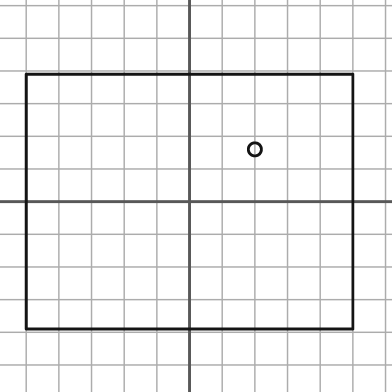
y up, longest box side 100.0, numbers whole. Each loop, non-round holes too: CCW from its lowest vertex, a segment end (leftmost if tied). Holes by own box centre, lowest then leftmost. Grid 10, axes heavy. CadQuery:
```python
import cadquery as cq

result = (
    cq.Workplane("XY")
    .moveTo(-50.0, -39.0)
    .lineTo(50.0, -39.0)
    .lineTo(50.0, 39.0)
    .lineTo(-50.0, 39.0)
    .close()
    .moveTo(20.0, 16.0)
    .circle(2.0)
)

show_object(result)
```